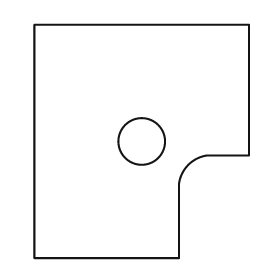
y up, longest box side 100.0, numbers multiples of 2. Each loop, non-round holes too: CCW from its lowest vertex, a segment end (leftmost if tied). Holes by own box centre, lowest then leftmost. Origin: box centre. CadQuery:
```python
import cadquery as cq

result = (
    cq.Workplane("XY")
    .moveTo(-46.0, -50.0)
    .lineTo(16.0, -50.0)
    .lineTo(16.0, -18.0)
    .threePointArc((20.0, -10.0), (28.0, -6.0))
    .lineTo(46.0, -6.0)
    .lineTo(46.0, 50.0)
    .lineTo(-46.0, 50.0)
    .close()
    .moveTo(0.0, 0.0)
    .circle(10.0)
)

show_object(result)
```